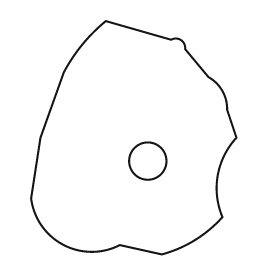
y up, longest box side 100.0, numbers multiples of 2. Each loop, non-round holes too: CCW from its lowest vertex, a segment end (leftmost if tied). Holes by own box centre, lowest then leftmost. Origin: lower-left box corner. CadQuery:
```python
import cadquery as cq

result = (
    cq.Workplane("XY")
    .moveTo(56.0, 0.0)
    .threePointArc((70.0, 6.0), (82.0, 16.0))
    .threePointArc((80.0, 34.0), (88.0, 50.0))
    .lineTo(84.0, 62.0)
    .threePointArc((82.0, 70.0), (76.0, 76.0))
    .lineTo(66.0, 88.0)
    .threePointArc((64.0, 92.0), (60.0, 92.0))
    .lineTo(32.0, 100.0)
    .threePointArc((22.0, 90.0), (14.0, 78.0))
    .lineTo(4.0, 50.0)
    .lineTo(0.0, 24.0)
    .threePointArc((14.0, 4.0), (38.0, 4.0))
    .close()
    .moveTo(50.0, 40.0)
    .circle(8.0)
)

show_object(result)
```